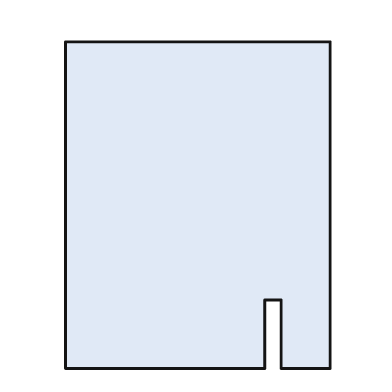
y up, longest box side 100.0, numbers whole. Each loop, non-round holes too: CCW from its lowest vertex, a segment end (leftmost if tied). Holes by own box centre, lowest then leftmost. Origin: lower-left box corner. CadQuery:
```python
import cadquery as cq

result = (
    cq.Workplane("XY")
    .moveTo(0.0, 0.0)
    .lineTo(61.0, 0.0)
    .lineTo(61.0, 21.0)
    .lineTo(66.0, 21.0)
    .lineTo(66.0, 0.0)
    .lineTo(81.0, 0.0)
    .lineTo(81.0, 100.0)
    .lineTo(0.0, 100.0)
    .close()
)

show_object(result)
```